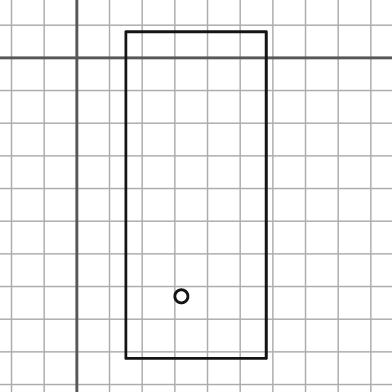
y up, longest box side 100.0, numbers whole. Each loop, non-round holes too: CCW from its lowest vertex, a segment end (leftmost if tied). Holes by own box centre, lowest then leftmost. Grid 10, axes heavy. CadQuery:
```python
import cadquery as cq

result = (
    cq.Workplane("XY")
    .moveTo(15.0, -92.0)
    .lineTo(58.0, -92.0)
    .lineTo(58.0, 8.0)
    .lineTo(15.0, 8.0)
    .close()
    .moveTo(32.0, -73.0)
    .circle(2.0)
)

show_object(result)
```